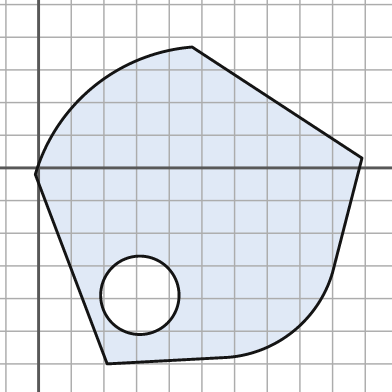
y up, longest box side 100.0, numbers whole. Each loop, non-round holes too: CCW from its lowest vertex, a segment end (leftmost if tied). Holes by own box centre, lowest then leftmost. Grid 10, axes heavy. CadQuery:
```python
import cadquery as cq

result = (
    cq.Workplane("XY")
    .moveTo(21.0, -60.0)
    .lineTo(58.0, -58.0)
    .threePointArc((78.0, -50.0), (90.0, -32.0))
    .lineTo(99.0, 3.0)
    .lineTo(47.0, 37.0)
    .threePointArc((17.0, 25.0), (-1.0, -2.0))
    .close()
    .moveTo(31.0, -39.0)
    .circle(12.0)
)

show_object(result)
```